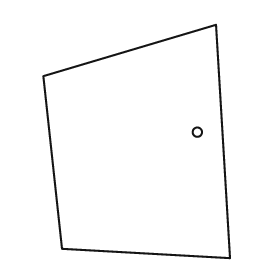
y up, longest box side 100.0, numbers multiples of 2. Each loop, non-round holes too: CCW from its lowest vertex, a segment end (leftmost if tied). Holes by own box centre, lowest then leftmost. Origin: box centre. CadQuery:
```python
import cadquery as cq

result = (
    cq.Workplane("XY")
    .moveTo(40.0, -50.0)
    .lineTo(34.0, 50.0)
    .lineTo(-40.0, 28.0)
    .lineTo(-32.0, -46.0)
    .close()
    .moveTo(26.0, 4.0)
    .circle(2.0)
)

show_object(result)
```